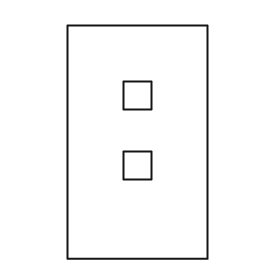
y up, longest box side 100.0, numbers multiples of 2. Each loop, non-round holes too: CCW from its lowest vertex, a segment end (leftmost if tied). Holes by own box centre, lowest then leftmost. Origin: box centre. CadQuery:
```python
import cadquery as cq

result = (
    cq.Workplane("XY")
    .moveTo(-30.0, -50.0)
    .lineTo(30.0, -50.0)
    .lineTo(30.0, 50.0)
    .lineTo(-30.0, 50.0)
    .close()
    .moveTo(-6.0, -16.0)
    .lineTo(6.0, -16.0)
    .lineTo(6.0, -4.0)
    .lineTo(-6.0, -4.0)
    .close()
    .moveTo(-6.0, 14.0)
    .lineTo(6.0, 14.0)
    .lineTo(6.0, 26.0)
    .lineTo(-6.0, 26.0)
    .close()
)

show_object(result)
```